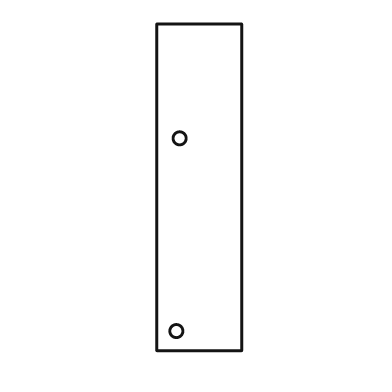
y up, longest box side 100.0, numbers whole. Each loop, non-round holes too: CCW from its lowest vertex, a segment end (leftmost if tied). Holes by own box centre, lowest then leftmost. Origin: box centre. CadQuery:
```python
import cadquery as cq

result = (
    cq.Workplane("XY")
    .moveTo(-13.0, -50.0)
    .lineTo(13.0, -50.0)
    .lineTo(13.0, 50.0)
    .lineTo(-13.0, 50.0)
    .close()
    .moveTo(-7.0, -44.0)
    .circle(2.0)
    .moveTo(-6.0, 15.0)
    .circle(2.0)
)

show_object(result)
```